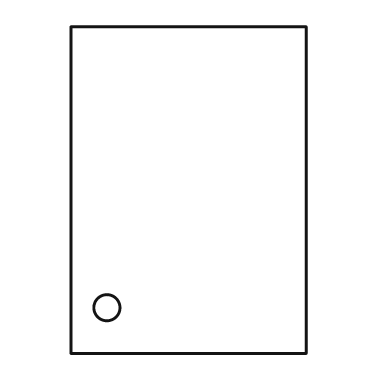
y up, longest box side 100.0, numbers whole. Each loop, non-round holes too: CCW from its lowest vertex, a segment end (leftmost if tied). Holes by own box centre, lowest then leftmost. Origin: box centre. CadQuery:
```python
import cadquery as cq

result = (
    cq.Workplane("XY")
    .moveTo(-36.0, -50.0)
    .lineTo(36.0, -50.0)
    .lineTo(36.0, 50.0)
    .lineTo(-36.0, 50.0)
    .close()
    .moveTo(-25.0, -36.0)
    .circle(4.0)
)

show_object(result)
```